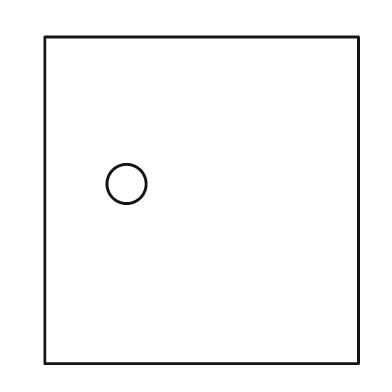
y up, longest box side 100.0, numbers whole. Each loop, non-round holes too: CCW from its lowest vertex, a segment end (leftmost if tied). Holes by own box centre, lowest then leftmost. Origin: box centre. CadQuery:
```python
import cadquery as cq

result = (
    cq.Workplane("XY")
    .moveTo(-48.0, -50.0)
    .lineTo(48.0, -50.0)
    .lineTo(48.0, 50.0)
    .lineTo(-48.0, 50.0)
    .close()
    .moveTo(-23.0, 5.0)
    .circle(6.0)
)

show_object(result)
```